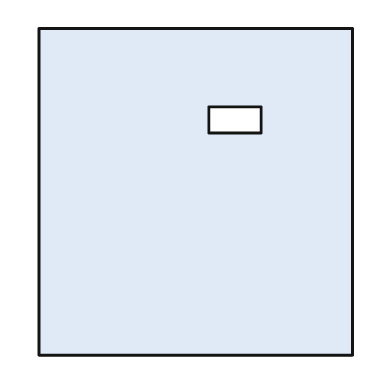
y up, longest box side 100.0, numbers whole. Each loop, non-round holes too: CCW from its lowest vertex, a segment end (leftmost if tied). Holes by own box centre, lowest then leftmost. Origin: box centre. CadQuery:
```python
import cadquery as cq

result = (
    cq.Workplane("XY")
    .moveTo(-48.0, -50.0)
    .lineTo(48.0, -50.0)
    .lineTo(48.0, 50.0)
    .lineTo(-48.0, 50.0)
    .close()
    .moveTo(4.0, 18.0)
    .lineTo(20.0, 18.0)
    .lineTo(20.0, 26.0)
    .lineTo(4.0, 26.0)
    .close()
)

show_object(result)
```